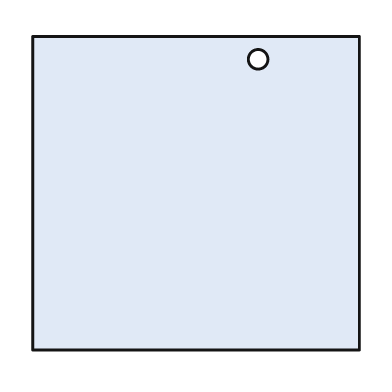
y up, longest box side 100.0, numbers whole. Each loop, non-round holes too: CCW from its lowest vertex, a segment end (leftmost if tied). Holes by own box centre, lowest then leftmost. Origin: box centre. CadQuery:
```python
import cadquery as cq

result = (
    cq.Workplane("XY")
    .moveTo(-50.0, -48.0)
    .lineTo(50.0, -48.0)
    .lineTo(50.0, 48.0)
    .lineTo(-50.0, 48.0)
    .close()
    .moveTo(19.0, 41.0)
    .circle(3.0)
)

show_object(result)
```